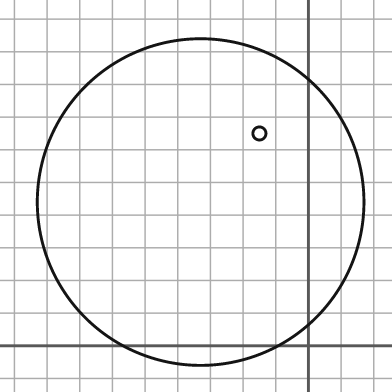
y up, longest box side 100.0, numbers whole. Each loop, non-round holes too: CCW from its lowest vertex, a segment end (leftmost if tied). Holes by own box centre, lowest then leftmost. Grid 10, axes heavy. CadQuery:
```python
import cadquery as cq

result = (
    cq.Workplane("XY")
    .moveTo(-33.0, 44.0)
    .circle(50.0)
    .moveTo(-15.0, 65.0)
    .circle(2.0)
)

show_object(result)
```